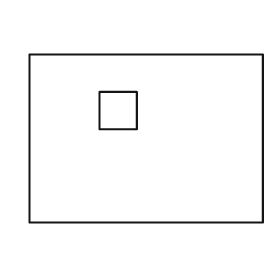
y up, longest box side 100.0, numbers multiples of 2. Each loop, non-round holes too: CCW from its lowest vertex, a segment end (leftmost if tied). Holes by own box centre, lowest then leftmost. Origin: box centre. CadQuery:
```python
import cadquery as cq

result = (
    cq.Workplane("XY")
    .moveTo(-50.0, -36.0)
    .lineTo(50.0, -36.0)
    .lineTo(50.0, 36.0)
    .lineTo(-50.0, 36.0)
    .close()
    .moveTo(-20.0, 4.0)
    .lineTo(-4.0, 4.0)
    .lineTo(-4.0, 20.0)
    .lineTo(-20.0, 20.0)
    .close()
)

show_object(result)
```